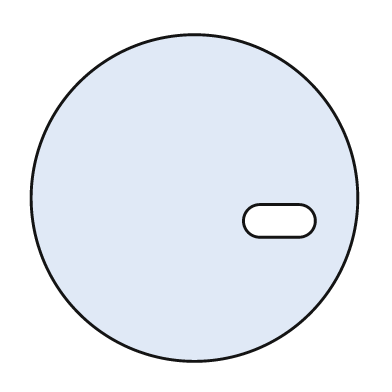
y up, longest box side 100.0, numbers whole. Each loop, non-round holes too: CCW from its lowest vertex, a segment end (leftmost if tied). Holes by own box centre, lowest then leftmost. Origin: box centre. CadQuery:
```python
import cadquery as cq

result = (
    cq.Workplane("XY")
    .moveTo(0.0, 0.0)
    .circle(50.0)
    .moveTo(20.0, -12.0)
    .lineTo(32.0, -12.0)
    .threePointArc((37.0, -7.0), (32.0, -2.0))
    .lineTo(20.0, -2.0)
    .threePointArc((15.0, -7.0), (20.0, -12.0))
    .close()
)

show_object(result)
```